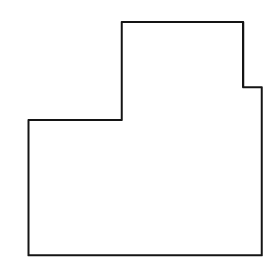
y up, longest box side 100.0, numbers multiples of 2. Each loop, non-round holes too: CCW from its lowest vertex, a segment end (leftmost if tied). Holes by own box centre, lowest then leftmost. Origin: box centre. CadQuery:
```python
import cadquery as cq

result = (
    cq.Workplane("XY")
    .moveTo(-50.0, -50.0)
    .lineTo(50.0, -50.0)
    .lineTo(50.0, 22.0)
    .lineTo(42.0, 22.0)
    .lineTo(42.0, 50.0)
    .lineTo(-10.0, 50.0)
    .lineTo(-10.0, 8.0)
    .lineTo(-50.0, 8.0)
    .close()
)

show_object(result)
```